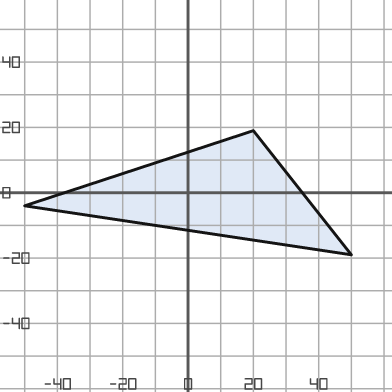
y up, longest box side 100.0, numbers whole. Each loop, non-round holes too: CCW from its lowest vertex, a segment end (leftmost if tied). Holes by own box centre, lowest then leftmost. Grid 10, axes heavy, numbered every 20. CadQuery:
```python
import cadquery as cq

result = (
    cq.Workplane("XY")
    .moveTo(50.0, -19.0)
    .lineTo(20.0, 19.0)
    .lineTo(-50.0, -4.0)
    .close()
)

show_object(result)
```